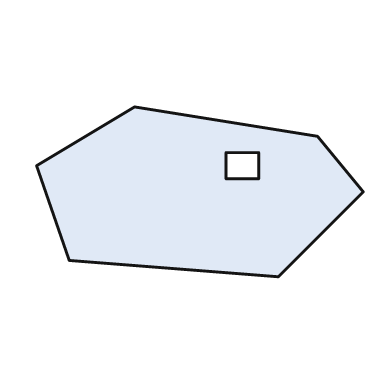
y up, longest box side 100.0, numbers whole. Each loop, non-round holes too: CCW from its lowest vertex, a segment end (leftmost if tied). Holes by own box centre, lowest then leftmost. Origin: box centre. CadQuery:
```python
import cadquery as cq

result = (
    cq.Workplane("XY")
    .moveTo(24.0, -26.0)
    .lineTo(50.0, 0.0)
    .lineTo(36.0, 17.0)
    .lineTo(-20.0, 26.0)
    .lineTo(-50.0, 8.0)
    .lineTo(-40.0, -21.0)
    .close()
    .moveTo(8.0, 4.0)
    .lineTo(18.0, 4.0)
    .lineTo(18.0, 12.0)
    .lineTo(8.0, 12.0)
    .close()
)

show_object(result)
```